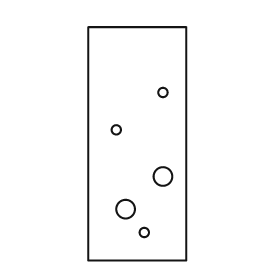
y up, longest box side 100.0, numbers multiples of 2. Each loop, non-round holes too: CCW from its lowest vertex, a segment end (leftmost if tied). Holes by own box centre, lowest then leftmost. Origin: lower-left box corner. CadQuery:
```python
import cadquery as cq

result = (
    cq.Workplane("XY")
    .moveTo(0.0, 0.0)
    .lineTo(42.0, 0.0)
    .lineTo(42.0, 100.0)
    .lineTo(0.0, 100.0)
    .close()
    .moveTo(24.0, 12.0)
    .circle(2.0)
    .moveTo(16.0, 22.0)
    .circle(4.0)
    .moveTo(32.0, 36.0)
    .circle(4.0)
    .moveTo(12.0, 56.0)
    .circle(2.0)
    .moveTo(32.0, 72.0)
    .circle(2.0)
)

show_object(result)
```